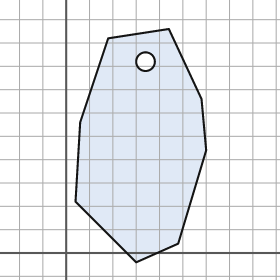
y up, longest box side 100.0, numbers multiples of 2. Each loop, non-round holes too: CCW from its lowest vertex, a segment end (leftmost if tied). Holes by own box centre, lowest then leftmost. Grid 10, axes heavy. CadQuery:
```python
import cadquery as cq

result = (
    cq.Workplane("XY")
    .moveTo(30.0, -4.0)
    .lineTo(48.0, 4.0)
    .lineTo(60.0, 44.0)
    .lineTo(58.0, 66.0)
    .lineTo(44.0, 96.0)
    .lineTo(18.0, 92.0)
    .lineTo(6.0, 56.0)
    .lineTo(4.0, 22.0)
    .close()
    .moveTo(34.0, 82.0)
    .circle(4.0)
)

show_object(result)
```